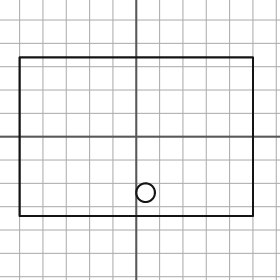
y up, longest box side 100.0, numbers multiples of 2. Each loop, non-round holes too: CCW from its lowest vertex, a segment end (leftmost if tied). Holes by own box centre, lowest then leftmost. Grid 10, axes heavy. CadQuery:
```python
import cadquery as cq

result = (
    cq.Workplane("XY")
    .moveTo(-50.0, -34.0)
    .lineTo(50.0, -34.0)
    .lineTo(50.0, 34.0)
    .lineTo(-50.0, 34.0)
    .close()
    .moveTo(4.0, -24.0)
    .circle(4.0)
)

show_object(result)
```